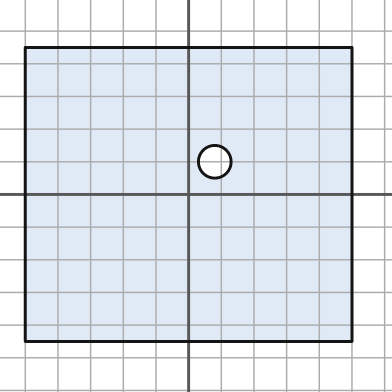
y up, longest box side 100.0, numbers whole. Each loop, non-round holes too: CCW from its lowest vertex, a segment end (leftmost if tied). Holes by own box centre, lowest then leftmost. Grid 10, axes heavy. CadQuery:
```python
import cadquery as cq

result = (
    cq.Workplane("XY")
    .moveTo(-50.0, -45.0)
    .lineTo(50.0, -45.0)
    .lineTo(50.0, 45.0)
    .lineTo(-50.0, 45.0)
    .close()
    .moveTo(8.0, 10.0)
    .circle(5.0)
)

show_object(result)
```